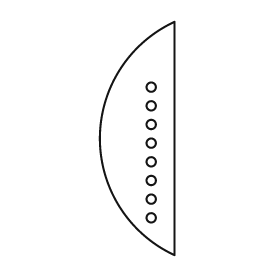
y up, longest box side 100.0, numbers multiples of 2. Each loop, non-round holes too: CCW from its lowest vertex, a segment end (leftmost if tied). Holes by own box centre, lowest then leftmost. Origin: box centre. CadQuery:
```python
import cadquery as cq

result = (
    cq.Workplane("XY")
    .moveTo(16.0, -50.0)
    .lineTo(16.0, 50.0)
    .threePointArc((-16.0, 0.0), (16.0, -50.0))
    .close()
    .moveTo(6.0, -34.0)
    .circle(2.0)
    .moveTo(6.0, -26.0)
    .circle(2.0)
    .moveTo(6.0, -18.0)
    .circle(2.0)
    .moveTo(6.0, -10.0)
    .circle(2.0)
    .moveTo(6.0, -2.0)
    .circle(2.0)
    .moveTo(6.0, 6.0)
    .circle(2.0)
    .moveTo(6.0, 14.0)
    .circle(2.0)
    .moveTo(6.0, 22.0)
    .circle(2.0)
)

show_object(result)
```